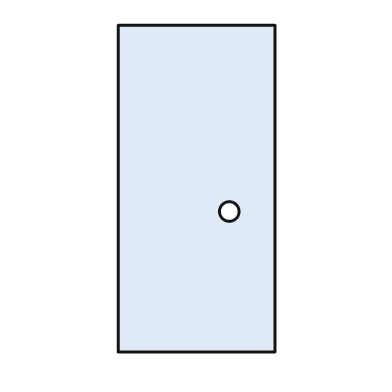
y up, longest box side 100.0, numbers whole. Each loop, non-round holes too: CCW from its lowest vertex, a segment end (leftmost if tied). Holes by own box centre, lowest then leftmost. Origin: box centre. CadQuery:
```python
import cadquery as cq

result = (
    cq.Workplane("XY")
    .moveTo(-24.0, -50.0)
    .lineTo(24.0, -50.0)
    .lineTo(24.0, 50.0)
    .lineTo(-24.0, 50.0)
    .close()
    .moveTo(10.0, -7.0)
    .circle(3.0)
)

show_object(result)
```